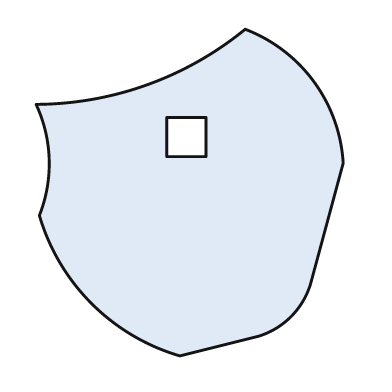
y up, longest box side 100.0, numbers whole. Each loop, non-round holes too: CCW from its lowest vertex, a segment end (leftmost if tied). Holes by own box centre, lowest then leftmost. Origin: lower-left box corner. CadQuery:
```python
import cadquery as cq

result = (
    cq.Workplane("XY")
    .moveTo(44.0, 0.0)
    .lineTo(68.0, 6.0)
    .threePointArc((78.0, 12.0), (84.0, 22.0))
    .lineTo(94.0, 59.0)
    .threePointArc((85.0, 84.0), (64.0, 100.0))
    .threePointArc((34.0, 83.0), (0.0, 77.0))
    .threePointArc((4.0, 60.0), (1.0, 43.0))
    .threePointArc((17.0, 16.0), (44.0, 0.0))
    .close()
    .moveTo(40.0, 61.0)
    .lineTo(52.0, 61.0)
    .lineTo(52.0, 73.0)
    .lineTo(40.0, 73.0)
    .close()
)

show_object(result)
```